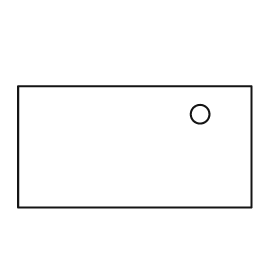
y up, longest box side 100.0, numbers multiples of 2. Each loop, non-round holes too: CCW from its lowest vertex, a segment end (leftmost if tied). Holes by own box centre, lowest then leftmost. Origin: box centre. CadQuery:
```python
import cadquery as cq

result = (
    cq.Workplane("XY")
    .moveTo(-50.0, -26.0)
    .lineTo(50.0, -26.0)
    .lineTo(50.0, 26.0)
    .lineTo(-50.0, 26.0)
    .close()
    .moveTo(28.0, 14.0)
    .circle(4.0)
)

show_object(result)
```